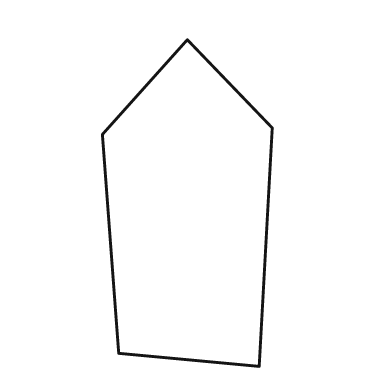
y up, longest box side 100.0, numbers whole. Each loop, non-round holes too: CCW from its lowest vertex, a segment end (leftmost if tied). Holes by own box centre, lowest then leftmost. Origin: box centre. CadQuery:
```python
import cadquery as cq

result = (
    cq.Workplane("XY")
    .moveTo(22.0, -50.0)
    .lineTo(26.0, 23.0)
    .lineTo(0.0, 50.0)
    .lineTo(-26.0, 21.0)
    .lineTo(-21.0, -46.0)
    .close()
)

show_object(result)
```